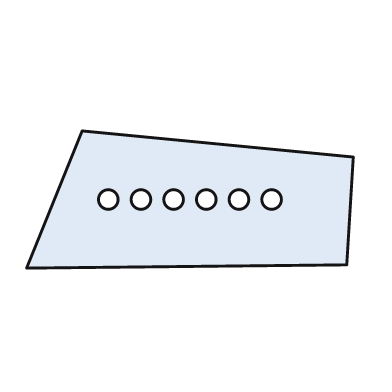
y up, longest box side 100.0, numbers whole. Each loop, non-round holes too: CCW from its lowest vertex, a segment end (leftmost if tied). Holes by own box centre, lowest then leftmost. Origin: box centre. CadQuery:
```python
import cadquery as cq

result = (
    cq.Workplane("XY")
    .moveTo(-50.0, -21.0)
    .lineTo(48.0, -20.0)
    .lineTo(50.0, 13.0)
    .lineTo(-33.0, 21.0)
    .close()
    .moveTo(-25.0, 0.0)
    .circle(3.0)
    .moveTo(-15.0, 0.0)
    .circle(3.0)
    .moveTo(-5.0, 0.0)
    .circle(3.0)
    .moveTo(5.0, 0.0)
    .circle(3.0)
    .moveTo(15.0, 0.0)
    .circle(3.0)
    .moveTo(25.0, 0.0)
    .circle(3.0)
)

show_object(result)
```